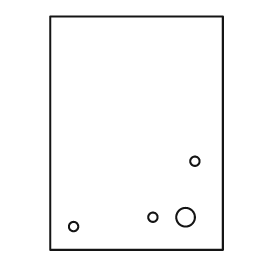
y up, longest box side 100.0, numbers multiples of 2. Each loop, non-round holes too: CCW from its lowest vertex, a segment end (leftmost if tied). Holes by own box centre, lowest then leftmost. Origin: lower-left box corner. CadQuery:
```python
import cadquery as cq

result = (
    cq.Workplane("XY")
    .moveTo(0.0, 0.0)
    .lineTo(74.0, 0.0)
    .lineTo(74.0, 100.0)
    .lineTo(0.0, 100.0)
    .close()
    .moveTo(10.0, 10.0)
    .circle(2.0)
    .moveTo(44.0, 14.0)
    .circle(2.0)
    .moveTo(58.0, 14.0)
    .circle(4.0)
    .moveTo(62.0, 38.0)
    .circle(2.0)
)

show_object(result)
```